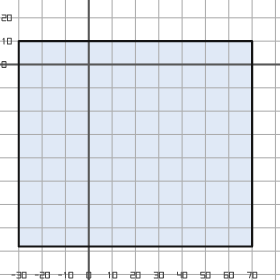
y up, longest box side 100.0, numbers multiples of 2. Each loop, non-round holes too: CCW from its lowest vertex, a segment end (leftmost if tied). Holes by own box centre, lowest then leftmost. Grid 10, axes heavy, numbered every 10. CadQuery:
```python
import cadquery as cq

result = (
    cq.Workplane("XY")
    .moveTo(-30.0, -78.0)
    .lineTo(70.0, -78.0)
    .lineTo(70.0, 10.0)
    .lineTo(-30.0, 10.0)
    .close()
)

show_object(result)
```